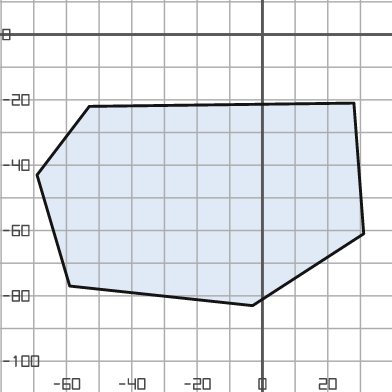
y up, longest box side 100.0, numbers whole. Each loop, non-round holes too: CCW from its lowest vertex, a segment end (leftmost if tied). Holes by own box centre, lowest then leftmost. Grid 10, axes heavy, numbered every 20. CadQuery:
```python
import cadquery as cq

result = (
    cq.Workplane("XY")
    .moveTo(-3.0, -83.0)
    .lineTo(31.0, -61.0)
    .lineTo(28.0, -21.0)
    .lineTo(-53.0, -22.0)
    .lineTo(-69.0, -43.0)
    .lineTo(-59.0, -77.0)
    .close()
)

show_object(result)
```